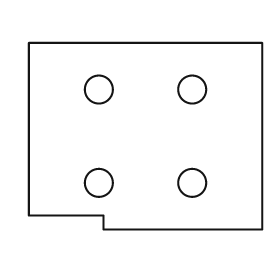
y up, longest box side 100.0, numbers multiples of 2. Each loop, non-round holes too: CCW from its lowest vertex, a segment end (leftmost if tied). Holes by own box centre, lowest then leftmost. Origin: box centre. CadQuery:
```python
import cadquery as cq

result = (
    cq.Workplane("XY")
    .moveTo(-18.0, -40.0)
    .lineTo(50.0, -40.0)
    .lineTo(50.0, 40.0)
    .lineTo(-50.0, 40.0)
    .lineTo(-50.0, -34.0)
    .lineTo(-18.0, -34.0)
    .close()
    .moveTo(-20.0, -20.0)
    .circle(6.0)
    .moveTo(20.0, -20.0)
    .circle(6.0)
    .moveTo(-20.0, 20.0)
    .circle(6.0)
    .moveTo(20.0, 20.0)
    .circle(6.0)
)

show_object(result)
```